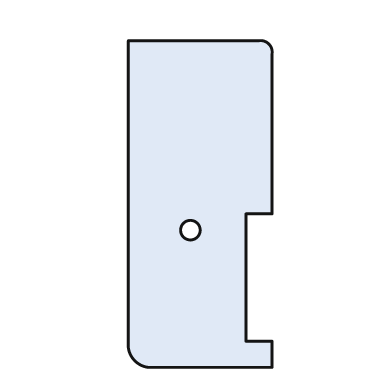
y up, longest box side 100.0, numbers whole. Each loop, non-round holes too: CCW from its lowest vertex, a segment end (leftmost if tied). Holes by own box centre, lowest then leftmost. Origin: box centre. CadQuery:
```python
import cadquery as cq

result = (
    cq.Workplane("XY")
    .moveTo(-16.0, -50.0)
    .lineTo(22.0, -50.0)
    .lineTo(22.0, -42.0)
    .lineTo(14.0, -42.0)
    .lineTo(14.0, -3.0)
    .lineTo(22.0, -3.0)
    .lineTo(22.0, 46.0)
    .threePointArc((21.0, 49.0), (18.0, 50.0))
    .lineTo(-22.0, 50.0)
    .lineTo(-22.0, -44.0)
    .threePointArc((-20.0, -48.0), (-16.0, -50.0))
    .close()
    .moveTo(-3.0, -8.0)
    .circle(3.0)
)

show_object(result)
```